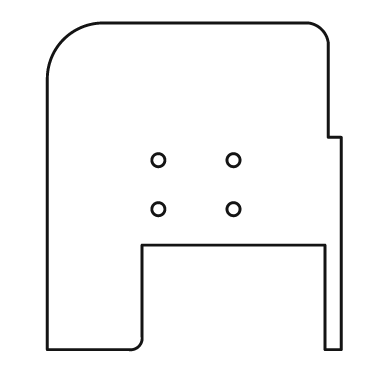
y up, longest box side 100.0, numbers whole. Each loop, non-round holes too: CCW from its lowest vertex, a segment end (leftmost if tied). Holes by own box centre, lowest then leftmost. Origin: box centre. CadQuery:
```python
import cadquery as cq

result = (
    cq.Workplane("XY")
    .moveTo(-45.0, -50.0)
    .lineTo(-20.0, -50.0)
    .threePointArc((-17.0, -49.0), (-16.0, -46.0))
    .lineTo(-16.0, -18.0)
    .lineTo(40.0, -18.0)
    .lineTo(40.0, -50.0)
    .lineTo(45.0, -50.0)
    .lineTo(45.0, 15.0)
    .lineTo(41.0, 15.0)
    .lineTo(41.0, 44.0)
    .threePointArc((39.0, 48.0), (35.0, 50.0))
    .lineTo(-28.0, 50.0)
    .threePointArc((-40.0, 45.0), (-45.0, 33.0))
    .close()
    .moveTo(-11.0, -7.0)
    .circle(2.0)
    .moveTo(12.0, -7.0)
    .circle(2.0)
    .moveTo(-11.0, 8.0)
    .circle(2.0)
    .moveTo(12.0, 8.0)
    .circle(2.0)
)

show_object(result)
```